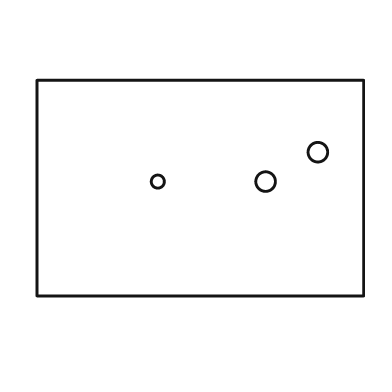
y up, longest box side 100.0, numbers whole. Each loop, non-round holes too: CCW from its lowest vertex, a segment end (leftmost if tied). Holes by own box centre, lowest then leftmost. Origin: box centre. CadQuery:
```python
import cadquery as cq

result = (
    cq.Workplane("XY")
    .moveTo(-50.0, -33.0)
    .lineTo(50.0, -33.0)
    .lineTo(50.0, 33.0)
    .lineTo(-50.0, 33.0)
    .close()
    .moveTo(-13.0, 2.0)
    .circle(2.0)
    .moveTo(20.0, 2.0)
    .circle(3.0)
    .moveTo(36.0, 11.0)
    .circle(3.0)
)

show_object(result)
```